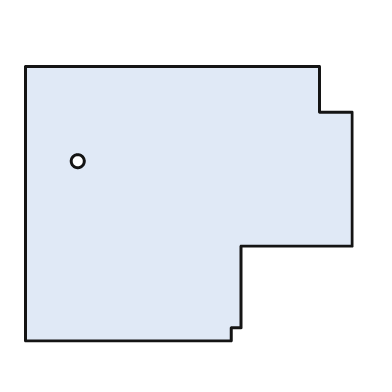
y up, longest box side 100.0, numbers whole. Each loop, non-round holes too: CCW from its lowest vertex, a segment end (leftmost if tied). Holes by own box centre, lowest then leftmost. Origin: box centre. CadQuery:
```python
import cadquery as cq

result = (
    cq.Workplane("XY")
    .moveTo(-50.0, -42.0)
    .lineTo(13.0, -42.0)
    .lineTo(13.0, -38.0)
    .lineTo(16.0, -38.0)
    .lineTo(16.0, -13.0)
    .lineTo(50.0, -13.0)
    .lineTo(50.0, 28.0)
    .lineTo(40.0, 28.0)
    .lineTo(40.0, 42.0)
    .lineTo(-50.0, 42.0)
    .close()
    .moveTo(-34.0, 13.0)
    .circle(2.0)
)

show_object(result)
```